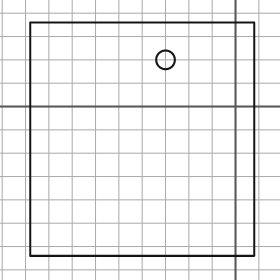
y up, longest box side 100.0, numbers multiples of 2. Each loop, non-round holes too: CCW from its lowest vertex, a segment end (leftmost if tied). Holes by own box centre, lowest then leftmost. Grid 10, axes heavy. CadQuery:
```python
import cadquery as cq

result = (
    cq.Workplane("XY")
    .moveTo(-88.0, -64.0)
    .lineTo(8.0, -64.0)
    .lineTo(8.0, 36.0)
    .lineTo(-88.0, 36.0)
    .close()
    .moveTo(-30.0, 20.0)
    .circle(4.0)
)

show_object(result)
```